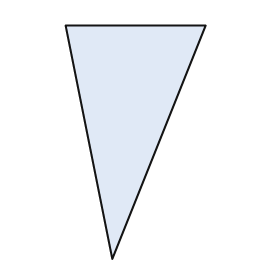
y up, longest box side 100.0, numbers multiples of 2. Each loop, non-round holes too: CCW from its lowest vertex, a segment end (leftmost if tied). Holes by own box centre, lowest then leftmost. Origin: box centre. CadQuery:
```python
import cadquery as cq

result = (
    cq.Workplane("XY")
    .moveTo(-10.0, -50.0)
    .lineTo(30.0, 50.0)
    .lineTo(-30.0, 50.0)
    .close()
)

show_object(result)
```